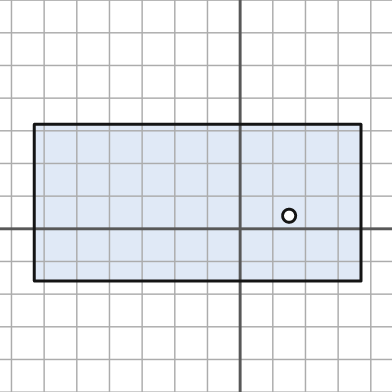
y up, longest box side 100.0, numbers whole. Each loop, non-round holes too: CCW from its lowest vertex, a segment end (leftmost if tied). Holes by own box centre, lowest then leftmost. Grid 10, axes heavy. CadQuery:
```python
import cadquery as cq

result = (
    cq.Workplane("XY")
    .moveTo(-63.0, -16.0)
    .lineTo(37.0, -16.0)
    .lineTo(37.0, 32.0)
    .lineTo(-63.0, 32.0)
    .close()
    .moveTo(15.0, 4.0)
    .circle(2.0)
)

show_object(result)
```